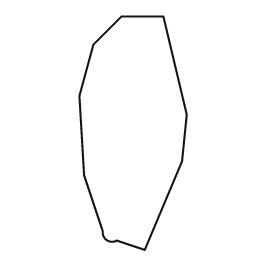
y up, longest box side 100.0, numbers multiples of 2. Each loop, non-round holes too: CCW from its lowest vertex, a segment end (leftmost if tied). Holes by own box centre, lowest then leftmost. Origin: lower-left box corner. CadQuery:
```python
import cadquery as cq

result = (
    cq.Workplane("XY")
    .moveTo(28.0, 0.0)
    .lineTo(44.0, 38.0)
    .lineTo(46.0, 58.0)
    .lineTo(36.0, 100.0)
    .lineTo(18.0, 100.0)
    .lineTo(6.0, 88.0)
    .lineTo(0.0, 66.0)
    .lineTo(2.0, 32.0)
    .lineTo(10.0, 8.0)
    .threePointArc((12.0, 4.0), (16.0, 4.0))
    .close()
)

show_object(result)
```